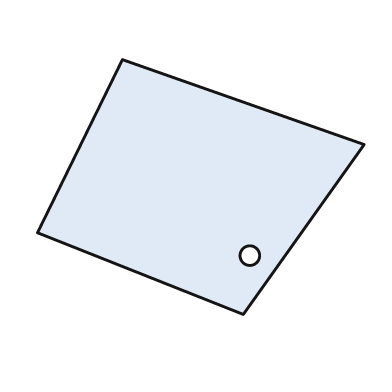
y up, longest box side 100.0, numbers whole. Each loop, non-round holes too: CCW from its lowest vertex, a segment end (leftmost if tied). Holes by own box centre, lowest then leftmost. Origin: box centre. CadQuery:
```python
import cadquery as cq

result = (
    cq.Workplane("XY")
    .moveTo(13.0, -39.0)
    .lineTo(50.0, 13.0)
    .lineTo(-24.0, 39.0)
    .lineTo(-50.0, -14.0)
    .close()
    .moveTo(15.0, -21.0)
    .circle(3.0)
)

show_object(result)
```